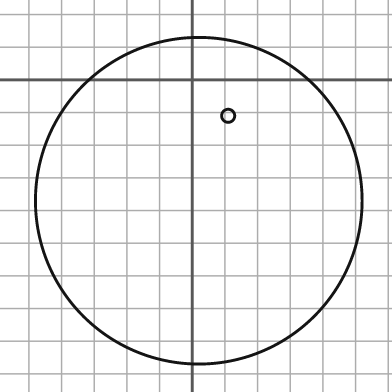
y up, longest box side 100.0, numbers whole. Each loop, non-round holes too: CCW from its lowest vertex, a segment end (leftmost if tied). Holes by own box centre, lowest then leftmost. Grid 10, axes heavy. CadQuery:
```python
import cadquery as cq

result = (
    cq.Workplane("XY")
    .moveTo(2.0, -37.0)
    .circle(50.0)
    .moveTo(11.0, -11.0)
    .circle(2.0)
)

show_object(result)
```